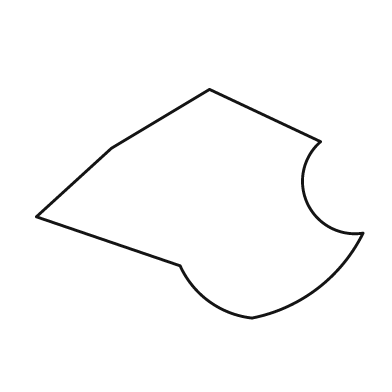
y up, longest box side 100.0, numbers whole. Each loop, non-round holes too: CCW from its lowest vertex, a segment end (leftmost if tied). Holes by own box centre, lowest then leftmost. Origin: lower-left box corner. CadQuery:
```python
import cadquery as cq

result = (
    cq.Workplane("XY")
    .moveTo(66.0, 0.0)
    .threePointArc((86.0, 9.0), (100.0, 26.0))
    .threePointArc((83.0, 35.0), (87.0, 54.0))
    .lineTo(53.0, 70.0)
    .lineTo(23.0, 52.0)
    .lineTo(0.0, 31.0)
    .lineTo(44.0, 16.0)
    .threePointArc((53.0, 5.0), (66.0, 0.0))
    .close()
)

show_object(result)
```